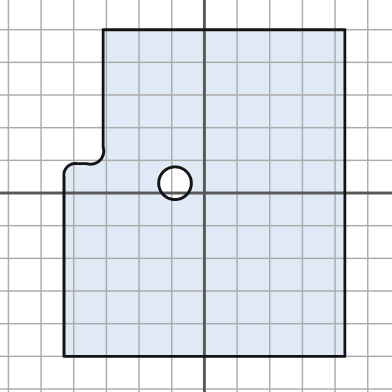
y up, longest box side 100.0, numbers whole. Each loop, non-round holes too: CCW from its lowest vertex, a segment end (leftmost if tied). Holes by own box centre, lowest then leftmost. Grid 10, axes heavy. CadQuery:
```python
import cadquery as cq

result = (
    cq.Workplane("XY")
    .moveTo(-43.0, -50.0)
    .lineTo(43.0, -50.0)
    .lineTo(43.0, 50.0)
    .lineTo(-31.0, 50.0)
    .lineTo(-31.0, 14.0)
    .threePointArc((-32.0, 10.0), (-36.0, 9.0))
    .lineTo(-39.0, 9.0)
    .threePointArc((-42.0, 8.0), (-43.0, 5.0))
    .close()
    .moveTo(-9.0, 3.0)
    .circle(5.0)
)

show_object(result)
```